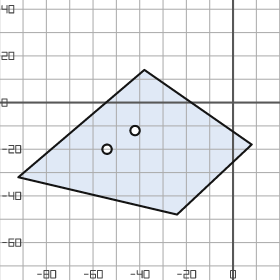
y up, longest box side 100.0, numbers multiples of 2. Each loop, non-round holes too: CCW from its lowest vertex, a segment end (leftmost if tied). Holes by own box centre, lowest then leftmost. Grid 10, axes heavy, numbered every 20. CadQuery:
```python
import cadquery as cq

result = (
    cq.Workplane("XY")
    .moveTo(-24.0, -48.0)
    .lineTo(8.0, -18.0)
    .lineTo(-38.0, 14.0)
    .lineTo(-92.0, -32.0)
    .close()
    .moveTo(-54.0, -20.0)
    .circle(2.0)
    .moveTo(-42.0, -12.0)
    .circle(2.0)
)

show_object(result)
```